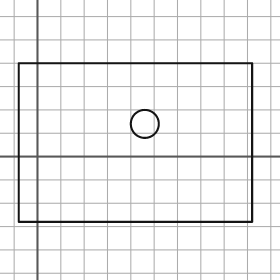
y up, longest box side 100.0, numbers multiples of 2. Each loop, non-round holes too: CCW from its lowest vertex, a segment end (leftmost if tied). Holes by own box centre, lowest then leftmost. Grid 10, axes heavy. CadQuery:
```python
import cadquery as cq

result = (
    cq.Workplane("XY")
    .moveTo(-8.0, -28.0)
    .lineTo(92.0, -28.0)
    .lineTo(92.0, 40.0)
    .lineTo(-8.0, 40.0)
    .close()
    .moveTo(46.0, 14.0)
    .circle(6.0)
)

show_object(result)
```